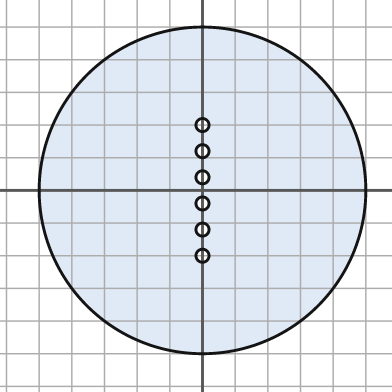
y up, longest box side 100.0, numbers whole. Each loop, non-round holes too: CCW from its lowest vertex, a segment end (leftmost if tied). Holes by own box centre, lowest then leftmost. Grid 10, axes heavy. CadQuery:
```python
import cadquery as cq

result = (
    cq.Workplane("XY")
    .moveTo(0.0, 0.0)
    .circle(50.0)
    .moveTo(0.0, -20.0)
    .circle(2.0)
    .moveTo(0.0, -12.0)
    .circle(2.0)
    .moveTo(0.0, -4.0)
    .circle(2.0)
    .moveTo(0.0, 4.0)
    .circle(2.0)
    .moveTo(0.0, 12.0)
    .circle(2.0)
    .moveTo(0.0, 20.0)
    .circle(2.0)
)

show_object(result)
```